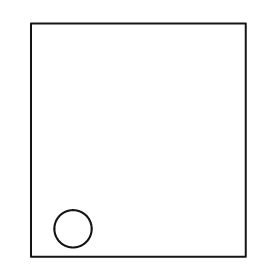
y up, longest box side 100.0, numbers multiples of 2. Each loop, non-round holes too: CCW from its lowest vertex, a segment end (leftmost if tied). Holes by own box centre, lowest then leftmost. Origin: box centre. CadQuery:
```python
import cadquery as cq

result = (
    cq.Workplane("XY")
    .moveTo(-46.0, -50.0)
    .lineTo(46.0, -50.0)
    .lineTo(46.0, 50.0)
    .lineTo(-46.0, 50.0)
    .close()
    .moveTo(-28.0, -38.0)
    .circle(8.0)
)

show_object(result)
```